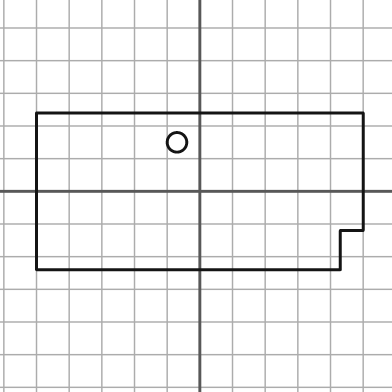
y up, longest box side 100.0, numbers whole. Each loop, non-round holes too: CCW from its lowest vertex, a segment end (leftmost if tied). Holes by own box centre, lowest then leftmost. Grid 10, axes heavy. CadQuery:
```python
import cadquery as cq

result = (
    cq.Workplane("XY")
    .moveTo(-50.0, -24.0)
    .lineTo(43.0, -24.0)
    .lineTo(43.0, -12.0)
    .lineTo(50.0, -12.0)
    .lineTo(50.0, 24.0)
    .lineTo(-50.0, 24.0)
    .close()
    .moveTo(-7.0, 15.0)
    .circle(3.0)
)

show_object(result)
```